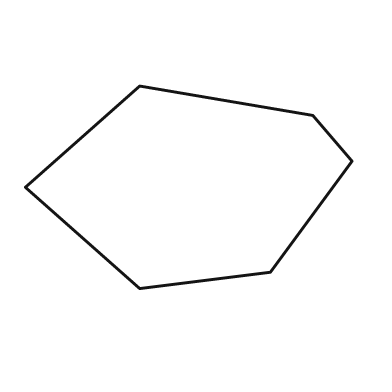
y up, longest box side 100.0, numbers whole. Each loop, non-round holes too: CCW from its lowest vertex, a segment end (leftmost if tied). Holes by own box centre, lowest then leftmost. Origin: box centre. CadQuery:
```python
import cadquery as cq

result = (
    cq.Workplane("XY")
    .moveTo(-15.0, -31.0)
    .lineTo(25.0, -26.0)
    .lineTo(50.0, 8.0)
    .lineTo(38.0, 22.0)
    .lineTo(-15.0, 31.0)
    .lineTo(-50.0, 0.0)
    .close()
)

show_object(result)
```